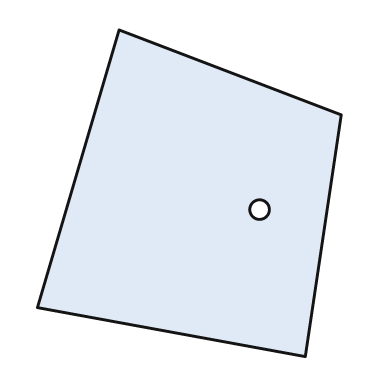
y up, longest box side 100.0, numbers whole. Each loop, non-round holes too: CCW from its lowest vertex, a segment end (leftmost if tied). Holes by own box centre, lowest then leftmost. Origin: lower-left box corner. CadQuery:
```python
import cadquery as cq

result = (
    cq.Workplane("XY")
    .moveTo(82.0, 0.0)
    .lineTo(93.0, 74.0)
    .lineTo(25.0, 100.0)
    .lineTo(0.0, 15.0)
    .close()
    .moveTo(68.0, 45.0)
    .circle(3.0)
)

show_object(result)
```